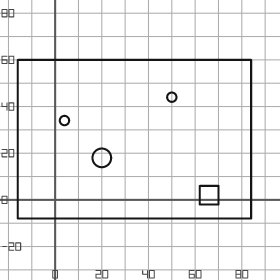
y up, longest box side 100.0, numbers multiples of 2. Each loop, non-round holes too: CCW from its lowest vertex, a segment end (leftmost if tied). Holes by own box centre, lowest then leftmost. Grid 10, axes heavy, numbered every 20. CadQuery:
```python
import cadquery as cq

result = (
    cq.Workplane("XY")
    .moveTo(-16.0, -8.0)
    .lineTo(84.0, -8.0)
    .lineTo(84.0, 60.0)
    .lineTo(-16.0, 60.0)
    .close()
    .moveTo(62.0, -2.0)
    .lineTo(70.0, -2.0)
    .lineTo(70.0, 6.0)
    .lineTo(62.0, 6.0)
    .close()
    .moveTo(20.0, 18.0)
    .circle(4.0)
    .moveTo(4.0, 34.0)
    .circle(2.0)
    .moveTo(50.0, 44.0)
    .circle(2.0)
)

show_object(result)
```